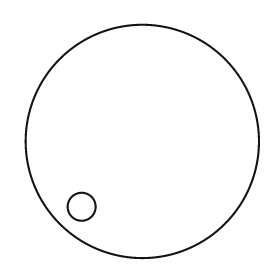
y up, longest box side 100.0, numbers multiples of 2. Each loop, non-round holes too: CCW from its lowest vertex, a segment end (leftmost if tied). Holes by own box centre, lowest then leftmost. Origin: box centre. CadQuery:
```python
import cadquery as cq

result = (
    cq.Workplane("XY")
    .moveTo(0.0, 0.0)
    .circle(50.0)
    .moveTo(-26.0, -28.0)
    .circle(6.0)
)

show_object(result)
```